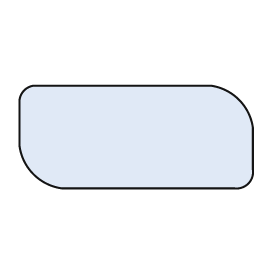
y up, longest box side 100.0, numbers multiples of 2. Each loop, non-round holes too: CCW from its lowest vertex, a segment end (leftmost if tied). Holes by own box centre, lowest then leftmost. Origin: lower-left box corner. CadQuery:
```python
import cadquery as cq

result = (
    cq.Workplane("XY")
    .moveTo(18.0, 0.0)
    .lineTo(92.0, 0.0)
    .threePointArc((98.0, 2.0), (100.0, 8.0))
    .lineTo(100.0, 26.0)
    .threePointArc((94.0, 38.0), (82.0, 44.0))
    .lineTo(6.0, 44.0)
    .threePointArc((2.0, 42.0), (0.0, 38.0))
    .lineTo(0.0, 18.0)
    .threePointArc((6.0, 6.0), (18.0, 0.0))
    .close()
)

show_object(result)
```